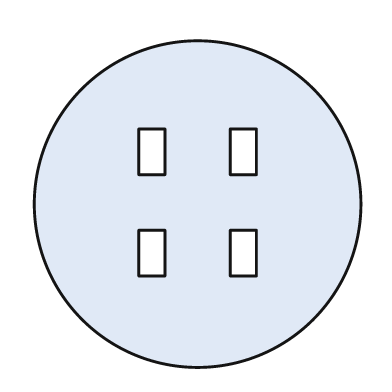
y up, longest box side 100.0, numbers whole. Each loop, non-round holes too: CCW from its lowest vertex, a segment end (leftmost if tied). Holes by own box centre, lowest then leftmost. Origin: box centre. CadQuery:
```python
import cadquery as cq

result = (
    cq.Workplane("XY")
    .moveTo(0.0, 0.0)
    .circle(50.0)
    .moveTo(-18.0, -22.0)
    .lineTo(-10.0, -22.0)
    .lineTo(-10.0, -8.0)
    .lineTo(-18.0, -8.0)
    .close()
    .moveTo(10.0, -22.0)
    .lineTo(18.0, -22.0)
    .lineTo(18.0, -8.0)
    .lineTo(10.0, -8.0)
    .close()
    .moveTo(-18.0, 9.0)
    .lineTo(-10.0, 9.0)
    .lineTo(-10.0, 23.0)
    .lineTo(-18.0, 23.0)
    .close()
    .moveTo(10.0, 9.0)
    .lineTo(18.0, 9.0)
    .lineTo(18.0, 23.0)
    .lineTo(10.0, 23.0)
    .close()
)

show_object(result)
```